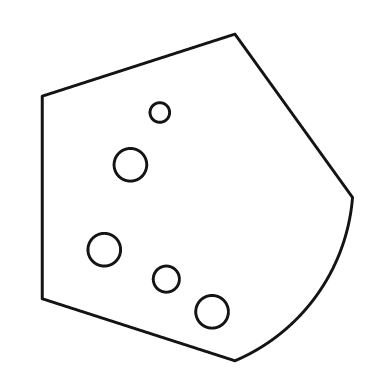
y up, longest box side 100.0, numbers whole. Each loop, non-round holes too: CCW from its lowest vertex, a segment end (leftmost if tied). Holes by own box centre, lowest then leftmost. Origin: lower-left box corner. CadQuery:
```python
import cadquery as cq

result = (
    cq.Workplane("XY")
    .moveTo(59.0, 0.0)
    .threePointArc((84.0, 20.0), (95.0, 50.0))
    .lineTo(59.0, 100.0)
    .lineTo(0.0, 81.0)
    .lineTo(0.0, 19.0)
    .close()
    .moveTo(52.0, 15.0)
    .circle(5.0)
    .moveTo(38.0, 25.0)
    .circle(4.0)
    .moveTo(19.0, 34.0)
    .circle(5.0)
    .moveTo(27.0, 60.0)
    .circle(5.0)
    .moveTo(36.0, 76.0)
    .circle(3.0)
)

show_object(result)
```